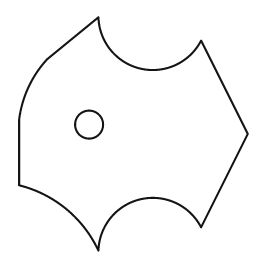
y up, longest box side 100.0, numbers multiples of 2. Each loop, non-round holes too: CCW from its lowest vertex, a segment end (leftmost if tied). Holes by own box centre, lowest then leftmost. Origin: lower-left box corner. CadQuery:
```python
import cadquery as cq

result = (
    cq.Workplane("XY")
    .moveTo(34.0, 0.0)
    .threePointArc((52.0, 22.0), (78.0, 10.0))
    .lineTo(98.0, 50.0)
    .lineTo(78.0, 90.0)
    .threePointArc((52.0, 78.0), (34.0, 100.0))
    .lineTo(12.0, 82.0)
    .threePointArc((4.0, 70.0), (0.0, 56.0))
    .lineTo(0.0, 28.0)
    .threePointArc((20.0, 18.0), (34.0, 0.0))
    .close()
    .moveTo(30.0, 54.0)
    .circle(6.0)
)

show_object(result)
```